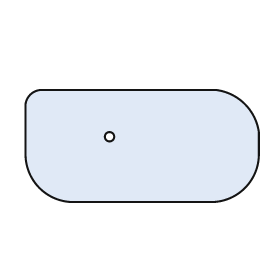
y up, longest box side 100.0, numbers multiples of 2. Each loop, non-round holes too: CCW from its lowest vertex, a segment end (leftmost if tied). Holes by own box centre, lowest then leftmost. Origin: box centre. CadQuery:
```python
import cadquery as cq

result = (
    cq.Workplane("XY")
    .moveTo(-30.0, -24.0)
    .lineTo(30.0, -24.0)
    .threePointArc((44.0, -18.0), (50.0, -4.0))
    .lineTo(50.0, 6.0)
    .threePointArc((44.0, 18.0), (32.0, 24.0))
    .lineTo(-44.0, 24.0)
    .threePointArc((-48.0, 22.0), (-50.0, 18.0))
    .lineTo(-50.0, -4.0)
    .threePointArc((-44.0, -18.0), (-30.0, -24.0))
    .close()
    .moveTo(-14.0, 4.0)
    .circle(2.0)
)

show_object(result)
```